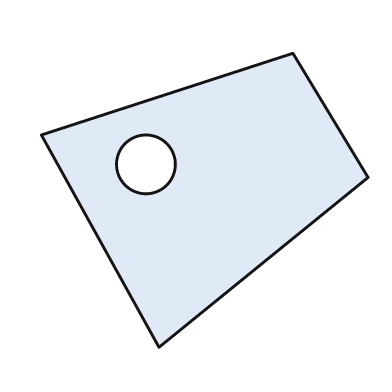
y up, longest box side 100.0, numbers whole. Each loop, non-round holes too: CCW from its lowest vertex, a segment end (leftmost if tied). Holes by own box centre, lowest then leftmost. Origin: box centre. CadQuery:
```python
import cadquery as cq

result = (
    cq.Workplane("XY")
    .moveTo(-14.0, -45.0)
    .lineTo(50.0, 7.0)
    .lineTo(27.0, 45.0)
    .lineTo(-50.0, 20.0)
    .close()
    .moveTo(-18.0, 11.0)
    .circle(9.0)
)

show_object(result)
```